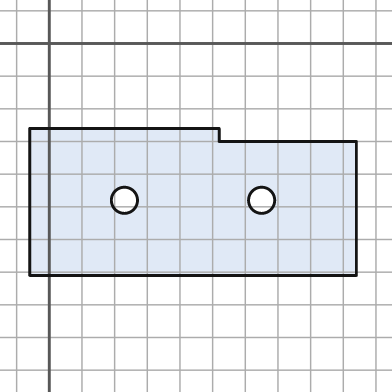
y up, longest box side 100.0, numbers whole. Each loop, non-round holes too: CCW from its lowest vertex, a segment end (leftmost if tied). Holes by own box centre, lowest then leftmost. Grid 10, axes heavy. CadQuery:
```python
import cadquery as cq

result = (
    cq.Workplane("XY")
    .moveTo(-6.0, -71.0)
    .lineTo(94.0, -71.0)
    .lineTo(94.0, -30.0)
    .lineTo(52.0, -30.0)
    .lineTo(52.0, -26.0)
    .lineTo(-6.0, -26.0)
    .close()
    .moveTo(23.0, -48.0)
    .circle(4.0)
    .moveTo(65.0, -48.0)
    .circle(4.0)
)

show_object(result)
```